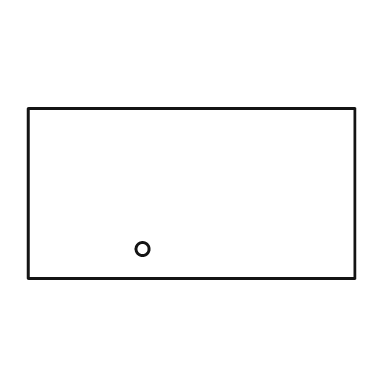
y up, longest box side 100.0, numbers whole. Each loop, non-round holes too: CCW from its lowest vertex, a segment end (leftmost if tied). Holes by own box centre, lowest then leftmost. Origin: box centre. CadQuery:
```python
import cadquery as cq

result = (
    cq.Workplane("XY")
    .moveTo(-50.0, -26.0)
    .lineTo(50.0, -26.0)
    .lineTo(50.0, 26.0)
    .lineTo(-50.0, 26.0)
    .close()
    .moveTo(-15.0, -17.0)
    .circle(2.0)
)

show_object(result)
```